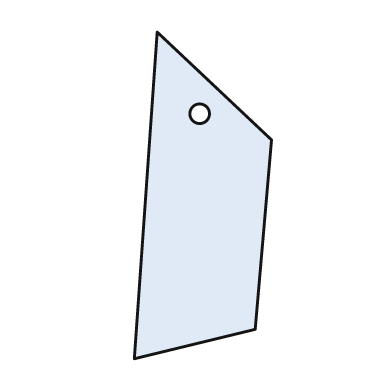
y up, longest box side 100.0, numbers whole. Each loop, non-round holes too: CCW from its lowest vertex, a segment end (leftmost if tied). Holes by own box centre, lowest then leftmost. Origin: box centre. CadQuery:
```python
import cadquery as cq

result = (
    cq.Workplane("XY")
    .moveTo(-21.0, -50.0)
    .lineTo(16.0, -41.0)
    .lineTo(21.0, 17.0)
    .lineTo(-14.0, 50.0)
    .close()
    .moveTo(-1.0, 25.0)
    .circle(3.0)
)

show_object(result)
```